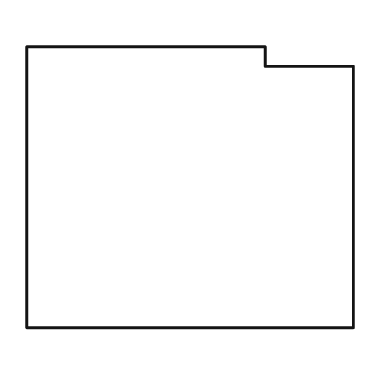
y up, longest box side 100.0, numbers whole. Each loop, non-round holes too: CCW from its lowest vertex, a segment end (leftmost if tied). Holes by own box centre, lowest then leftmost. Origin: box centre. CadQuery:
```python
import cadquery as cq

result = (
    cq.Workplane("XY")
    .moveTo(-50.0, -43.0)
    .lineTo(50.0, -43.0)
    .lineTo(50.0, 37.0)
    .lineTo(23.0, 37.0)
    .lineTo(23.0, 43.0)
    .lineTo(-50.0, 43.0)
    .close()
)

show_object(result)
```